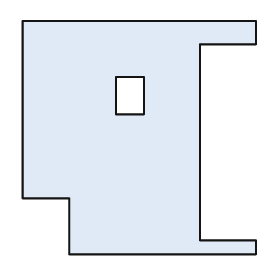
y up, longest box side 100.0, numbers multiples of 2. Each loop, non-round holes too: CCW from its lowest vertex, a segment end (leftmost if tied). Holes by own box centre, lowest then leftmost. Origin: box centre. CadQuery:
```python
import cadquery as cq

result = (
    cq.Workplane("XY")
    .moveTo(-30.0, -50.0)
    .lineTo(50.0, -50.0)
    .lineTo(50.0, -44.0)
    .lineTo(26.0, -44.0)
    .lineTo(26.0, 40.0)
    .lineTo(50.0, 40.0)
    .lineTo(50.0, 50.0)
    .lineTo(-50.0, 50.0)
    .lineTo(-50.0, -26.0)
    .lineTo(-30.0, -26.0)
    .close()
    .moveTo(-10.0, 10.0)
    .lineTo(2.0, 10.0)
    .lineTo(2.0, 26.0)
    .lineTo(-10.0, 26.0)
    .close()
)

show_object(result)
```